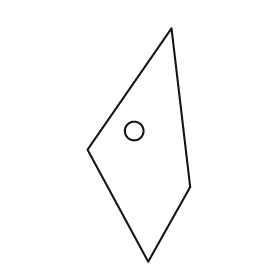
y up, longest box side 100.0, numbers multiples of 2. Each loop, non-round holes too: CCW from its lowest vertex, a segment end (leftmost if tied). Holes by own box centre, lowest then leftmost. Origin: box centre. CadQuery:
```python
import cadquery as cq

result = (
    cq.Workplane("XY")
    .moveTo(4.0, -50.0)
    .lineTo(22.0, -18.0)
    .lineTo(14.0, 50.0)
    .lineTo(-22.0, -2.0)
    .close()
    .moveTo(-2.0, 6.0)
    .circle(4.0)
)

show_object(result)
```